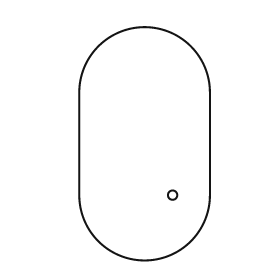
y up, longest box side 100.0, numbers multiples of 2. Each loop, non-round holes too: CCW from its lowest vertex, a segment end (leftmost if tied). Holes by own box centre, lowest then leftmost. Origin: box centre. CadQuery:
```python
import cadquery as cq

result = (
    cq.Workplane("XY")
    .moveTo(-28.0, -22.0)
    .threePointArc((0.0, -50.0), (28.0, -22.0))
    .lineTo(28.0, 22.0)
    .threePointArc((0.0, 50.0), (-28.0, 22.0))
    .close()
    .moveTo(12.0, -22.0)
    .circle(2.0)
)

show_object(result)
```